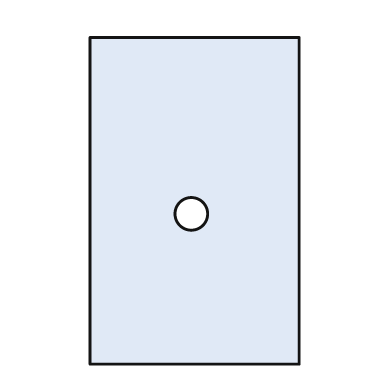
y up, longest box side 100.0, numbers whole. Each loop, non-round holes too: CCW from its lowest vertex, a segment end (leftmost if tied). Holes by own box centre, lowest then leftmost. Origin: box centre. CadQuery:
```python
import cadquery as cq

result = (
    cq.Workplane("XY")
    .moveTo(-32.0, -50.0)
    .lineTo(32.0, -50.0)
    .lineTo(32.0, 50.0)
    .lineTo(-32.0, 50.0)
    .close()
    .moveTo(-1.0, -4.0)
    .circle(5.0)
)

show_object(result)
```